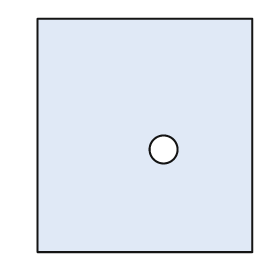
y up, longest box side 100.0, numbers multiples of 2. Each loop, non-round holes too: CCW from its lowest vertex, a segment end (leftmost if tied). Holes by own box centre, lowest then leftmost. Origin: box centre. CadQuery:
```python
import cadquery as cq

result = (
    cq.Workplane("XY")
    .moveTo(-46.0, -50.0)
    .lineTo(46.0, -50.0)
    .lineTo(46.0, 50.0)
    .lineTo(-46.0, 50.0)
    .close()
    .moveTo(8.0, -6.0)
    .circle(6.0)
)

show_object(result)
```